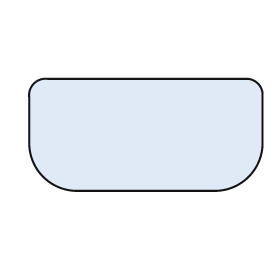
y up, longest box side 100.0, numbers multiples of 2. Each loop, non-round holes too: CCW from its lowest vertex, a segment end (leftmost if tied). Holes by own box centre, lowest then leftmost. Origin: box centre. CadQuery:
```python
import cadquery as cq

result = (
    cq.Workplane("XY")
    .moveTo(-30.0, -24.0)
    .lineTo(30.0, -24.0)
    .threePointArc((44.0, -18.0), (50.0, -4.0))
    .lineTo(50.0, 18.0)
    .threePointArc((48.0, 22.0), (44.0, 24.0))
    .lineTo(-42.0, 24.0)
    .threePointArc((-48.0, 22.0), (-50.0, 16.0))
    .lineTo(-50.0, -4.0)
    .threePointArc((-44.0, -18.0), (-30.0, -24.0))
    .close()
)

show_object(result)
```